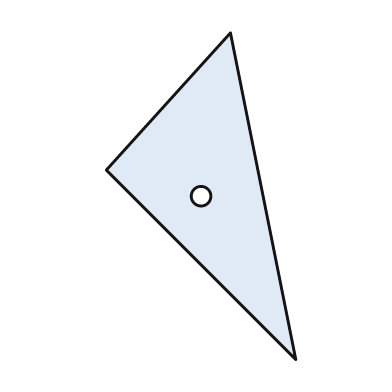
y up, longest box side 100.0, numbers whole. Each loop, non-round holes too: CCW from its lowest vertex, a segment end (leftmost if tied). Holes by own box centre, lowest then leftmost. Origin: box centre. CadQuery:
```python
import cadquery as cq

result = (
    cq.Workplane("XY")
    .moveTo(29.0, -50.0)
    .lineTo(9.0, 50.0)
    .lineTo(-29.0, 8.0)
    .close()
    .moveTo(0.0, 0.0)
    .circle(3.0)
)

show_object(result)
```